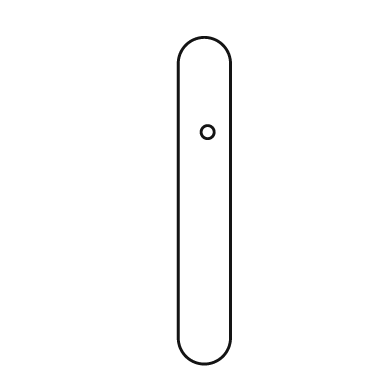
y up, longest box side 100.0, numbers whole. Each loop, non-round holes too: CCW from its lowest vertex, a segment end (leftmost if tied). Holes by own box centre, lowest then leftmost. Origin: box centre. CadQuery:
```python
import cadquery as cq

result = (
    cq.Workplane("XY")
    .moveTo(-8.0, -42.0)
    .threePointArc((0.0, -50.0), (8.0, -42.0))
    .lineTo(8.0, 42.0)
    .threePointArc((0.0, 50.0), (-8.0, 42.0))
    .close()
    .moveTo(1.0, 21.0)
    .circle(2.0)
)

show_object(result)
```